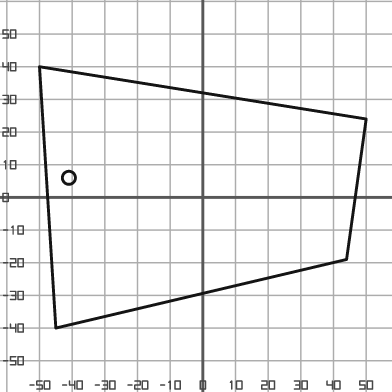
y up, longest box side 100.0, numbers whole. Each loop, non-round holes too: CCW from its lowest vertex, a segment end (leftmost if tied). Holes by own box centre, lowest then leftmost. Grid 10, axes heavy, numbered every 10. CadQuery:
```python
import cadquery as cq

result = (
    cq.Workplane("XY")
    .moveTo(-45.0, -40.0)
    .lineTo(44.0, -19.0)
    .lineTo(50.0, 24.0)
    .lineTo(-50.0, 40.0)
    .close()
    .moveTo(-41.0, 6.0)
    .circle(2.0)
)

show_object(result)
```